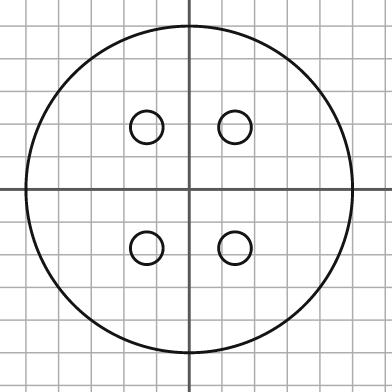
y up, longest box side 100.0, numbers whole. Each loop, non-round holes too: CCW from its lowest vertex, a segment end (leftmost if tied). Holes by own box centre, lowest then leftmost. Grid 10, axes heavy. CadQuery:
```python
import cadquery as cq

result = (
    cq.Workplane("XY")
    .moveTo(0.0, 0.0)
    .circle(50.0)
    .moveTo(-13.0, -18.0)
    .circle(5.0)
    .moveTo(14.0, -18.0)
    .circle(5.0)
    .moveTo(-13.0, 19.0)
    .circle(5.0)
    .moveTo(14.0, 19.0)
    .circle(5.0)
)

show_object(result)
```